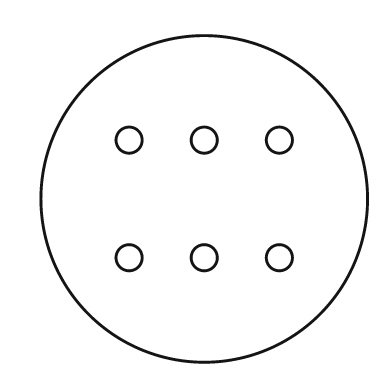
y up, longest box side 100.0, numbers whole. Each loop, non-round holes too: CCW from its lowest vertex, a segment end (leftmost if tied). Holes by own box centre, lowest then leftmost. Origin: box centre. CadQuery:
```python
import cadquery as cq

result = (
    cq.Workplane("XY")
    .moveTo(0.0, 0.0)
    .circle(50.0)
    .moveTo(-23.0, -18.0)
    .circle(4.0)
    .moveTo(0.0, -18.0)
    .circle(4.0)
    .moveTo(23.0, -18.0)
    .circle(4.0)
    .moveTo(-23.0, 18.0)
    .circle(4.0)
    .moveTo(0.0, 18.0)
    .circle(4.0)
    .moveTo(23.0, 18.0)
    .circle(4.0)
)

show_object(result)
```